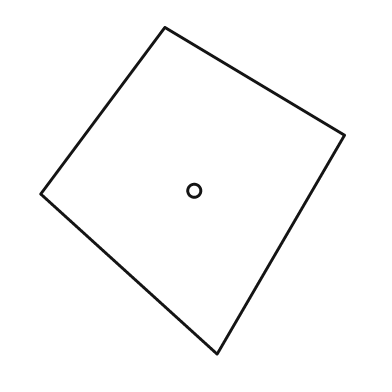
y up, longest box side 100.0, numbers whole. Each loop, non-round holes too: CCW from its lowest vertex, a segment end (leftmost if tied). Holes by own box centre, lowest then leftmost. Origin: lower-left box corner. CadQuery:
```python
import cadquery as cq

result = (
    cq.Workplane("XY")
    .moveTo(54.0, 0.0)
    .lineTo(93.0, 67.0)
    .lineTo(38.0, 100.0)
    .lineTo(0.0, 49.0)
    .close()
    .moveTo(47.0, 50.0)
    .circle(2.0)
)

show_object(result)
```